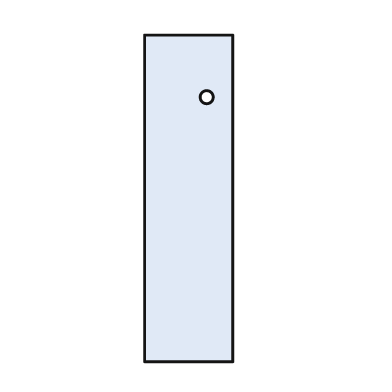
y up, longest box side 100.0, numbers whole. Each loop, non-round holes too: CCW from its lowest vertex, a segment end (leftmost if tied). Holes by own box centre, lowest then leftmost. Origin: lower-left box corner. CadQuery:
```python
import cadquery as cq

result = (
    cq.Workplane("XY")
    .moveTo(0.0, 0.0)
    .lineTo(27.0, 0.0)
    .lineTo(27.0, 100.0)
    .lineTo(0.0, 100.0)
    .close()
    .moveTo(19.0, 81.0)
    .circle(2.0)
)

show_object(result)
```